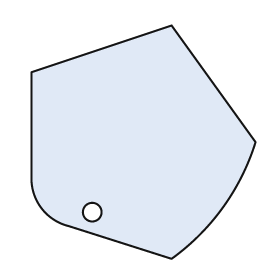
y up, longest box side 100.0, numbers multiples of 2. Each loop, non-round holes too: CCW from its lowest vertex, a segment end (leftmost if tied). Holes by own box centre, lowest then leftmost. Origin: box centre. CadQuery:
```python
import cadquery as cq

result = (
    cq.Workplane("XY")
    .moveTo(12.0, -50.0)
    .threePointArc((34.0, -28.0), (48.0, 0.0))
    .lineTo(12.0, 50.0)
    .lineTo(-48.0, 30.0)
    .lineTo(-48.0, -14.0)
    .threePointArc((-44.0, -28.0), (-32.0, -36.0))
    .close()
    .moveTo(-22.0, -30.0)
    .circle(4.0)
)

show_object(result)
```